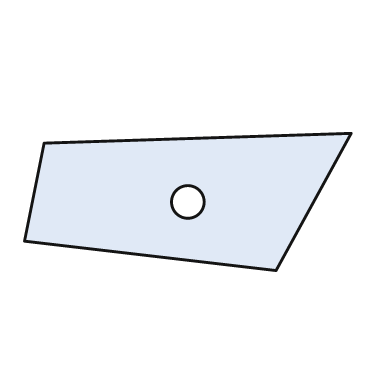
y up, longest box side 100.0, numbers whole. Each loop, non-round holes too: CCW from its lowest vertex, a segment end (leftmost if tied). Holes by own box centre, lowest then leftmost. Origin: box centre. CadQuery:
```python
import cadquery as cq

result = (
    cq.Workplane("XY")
    .moveTo(27.0, -21.0)
    .lineTo(50.0, 21.0)
    .lineTo(-44.0, 18.0)
    .lineTo(-50.0, -12.0)
    .close()
    .moveTo(0.0, 0.0)
    .circle(5.0)
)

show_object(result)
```